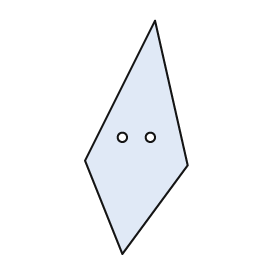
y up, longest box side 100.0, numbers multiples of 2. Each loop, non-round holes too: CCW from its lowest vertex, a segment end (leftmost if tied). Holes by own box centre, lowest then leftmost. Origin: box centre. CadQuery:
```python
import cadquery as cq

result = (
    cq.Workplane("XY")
    .moveTo(-6.0, -50.0)
    .lineTo(22.0, -12.0)
    .lineTo(8.0, 50.0)
    .lineTo(-22.0, -10.0)
    .close()
    .moveTo(-6.0, 0.0)
    .circle(2.0)
    .moveTo(6.0, 0.0)
    .circle(2.0)
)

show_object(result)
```